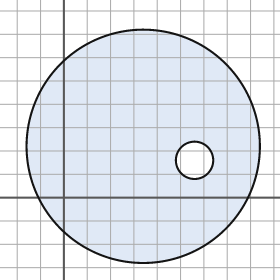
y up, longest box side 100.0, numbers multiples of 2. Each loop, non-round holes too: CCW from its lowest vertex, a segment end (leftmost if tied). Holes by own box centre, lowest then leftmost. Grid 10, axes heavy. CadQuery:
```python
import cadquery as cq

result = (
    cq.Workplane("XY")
    .moveTo(34.0, 22.0)
    .circle(50.0)
    .moveTo(56.0, 16.0)
    .circle(8.0)
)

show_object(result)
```